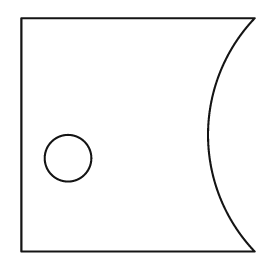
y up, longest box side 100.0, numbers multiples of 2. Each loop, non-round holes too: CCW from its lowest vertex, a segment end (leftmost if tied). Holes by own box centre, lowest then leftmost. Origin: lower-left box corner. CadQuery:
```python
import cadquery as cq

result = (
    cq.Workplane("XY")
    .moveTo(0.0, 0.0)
    .lineTo(100.0, 0.0)
    .threePointArc((80.0, 50.0), (100.0, 100.0))
    .lineTo(0.0, 100.0)
    .close()
    .moveTo(20.0, 40.0)
    .circle(10.0)
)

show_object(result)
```